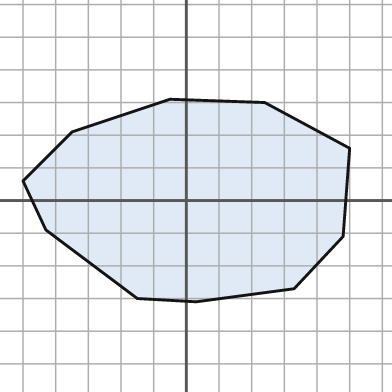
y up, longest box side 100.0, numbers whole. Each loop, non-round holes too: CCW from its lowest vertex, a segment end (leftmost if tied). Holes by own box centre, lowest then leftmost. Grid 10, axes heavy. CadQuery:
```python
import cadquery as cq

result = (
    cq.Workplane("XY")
    .moveTo(3.0, -31.0)
    .lineTo(33.0, -27.0)
    .lineTo(48.0, -11.0)
    .lineTo(50.0, 16.0)
    .lineTo(24.0, 30.0)
    .lineTo(-5.0, 31.0)
    .lineTo(-35.0, 21.0)
    .lineTo(-50.0, 6.0)
    .lineTo(-43.0, -9.0)
    .lineTo(-15.0, -30.0)
    .close()
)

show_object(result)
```